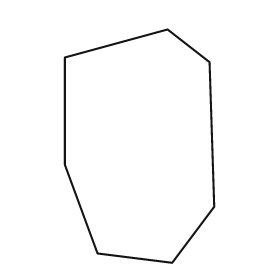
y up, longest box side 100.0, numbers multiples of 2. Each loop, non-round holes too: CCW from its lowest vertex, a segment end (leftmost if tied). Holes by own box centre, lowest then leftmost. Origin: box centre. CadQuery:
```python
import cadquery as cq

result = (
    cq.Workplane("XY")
    .moveTo(14.0, -50.0)
    .lineTo(32.0, -26.0)
    .lineTo(30.0, 36.0)
    .lineTo(12.0, 50.0)
    .lineTo(-32.0, 38.0)
    .lineTo(-32.0, -8.0)
    .lineTo(-18.0, -46.0)
    .close()
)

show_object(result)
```